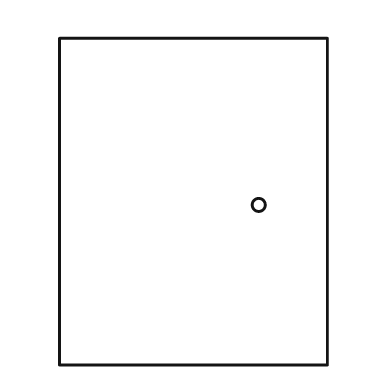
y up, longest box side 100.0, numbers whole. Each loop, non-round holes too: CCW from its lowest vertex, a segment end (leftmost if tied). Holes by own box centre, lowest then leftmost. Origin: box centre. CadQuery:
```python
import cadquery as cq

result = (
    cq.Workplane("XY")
    .moveTo(-41.0, -50.0)
    .lineTo(41.0, -50.0)
    .lineTo(41.0, 50.0)
    .lineTo(-41.0, 50.0)
    .close()
    .moveTo(20.0, -1.0)
    .circle(2.0)
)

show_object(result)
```